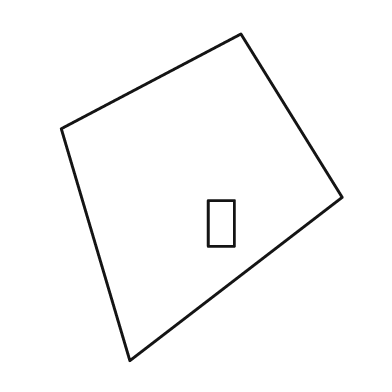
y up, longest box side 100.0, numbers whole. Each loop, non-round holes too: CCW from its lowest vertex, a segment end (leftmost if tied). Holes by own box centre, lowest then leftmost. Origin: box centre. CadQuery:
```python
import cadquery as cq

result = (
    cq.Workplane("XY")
    .moveTo(-22.0, -50.0)
    .lineTo(43.0, 0.0)
    .lineTo(12.0, 50.0)
    .lineTo(-43.0, 21.0)
    .close()
    .moveTo(2.0, -15.0)
    .lineTo(10.0, -15.0)
    .lineTo(10.0, -1.0)
    .lineTo(2.0, -1.0)
    .close()
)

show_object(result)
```